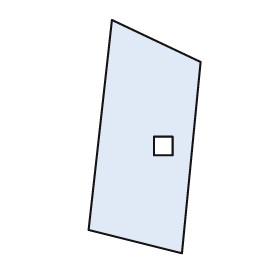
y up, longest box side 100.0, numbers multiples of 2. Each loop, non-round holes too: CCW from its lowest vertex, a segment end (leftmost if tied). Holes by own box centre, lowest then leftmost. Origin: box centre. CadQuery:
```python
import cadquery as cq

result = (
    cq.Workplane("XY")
    .moveTo(16.0, -50.0)
    .lineTo(24.0, 32.0)
    .lineTo(-14.0, 50.0)
    .lineTo(-24.0, -40.0)
    .close()
    .moveTo(4.0, -8.0)
    .lineTo(12.0, -8.0)
    .lineTo(12.0, 0.0)
    .lineTo(4.0, 0.0)
    .close()
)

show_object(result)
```